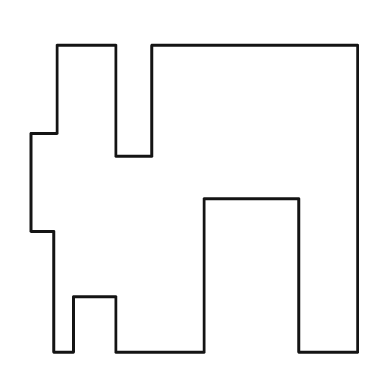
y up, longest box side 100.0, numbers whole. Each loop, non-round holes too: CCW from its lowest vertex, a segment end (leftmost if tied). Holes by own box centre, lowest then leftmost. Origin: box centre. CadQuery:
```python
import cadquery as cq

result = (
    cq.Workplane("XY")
    .moveTo(-43.0, -47.0)
    .lineTo(-37.0, -47.0)
    .lineTo(-37.0, -30.0)
    .lineTo(-24.0, -30.0)
    .lineTo(-24.0, -47.0)
    .lineTo(3.0, -47.0)
    .lineTo(3.0, 0.0)
    .lineTo(32.0, 0.0)
    .lineTo(32.0, -47.0)
    .lineTo(50.0, -47.0)
    .lineTo(50.0, 47.0)
    .lineTo(-13.0, 47.0)
    .lineTo(-13.0, 13.0)
    .lineTo(-24.0, 13.0)
    .lineTo(-24.0, 47.0)
    .lineTo(-42.0, 47.0)
    .lineTo(-42.0, 20.0)
    .lineTo(-50.0, 20.0)
    .lineTo(-50.0, -10.0)
    .lineTo(-43.0, -10.0)
    .close()
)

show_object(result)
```